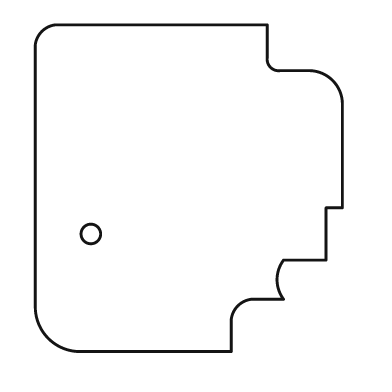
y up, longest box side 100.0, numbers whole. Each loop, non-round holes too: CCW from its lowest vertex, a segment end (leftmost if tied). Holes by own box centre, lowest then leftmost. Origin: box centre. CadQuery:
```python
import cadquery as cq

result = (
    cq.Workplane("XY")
    .moveTo(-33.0, -50.0)
    .lineTo(13.0, -50.0)
    .lineTo(13.0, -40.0)
    .threePointArc((15.0, -36.0), (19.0, -34.0))
    .lineTo(29.0, -34.0)
    .threePointArc((27.0, -28.0), (29.0, -22.0))
    .lineTo(42.0, -22.0)
    .lineTo(42.0, -6.0)
    .lineTo(47.0, -6.0)
    .lineTo(47.0, 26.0)
    .threePointArc((44.0, 33.0), (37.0, 36.0))
    .lineTo(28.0, 36.0)
    .threePointArc((25.0, 37.0), (24.0, 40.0))
    .lineTo(24.0, 50.0)
    .lineTo(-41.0, 50.0)
    .threePointArc((-45.0, 48.0), (-47.0, 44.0))
    .lineTo(-47.0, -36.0)
    .threePointArc((-43.0, -46.0), (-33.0, -50.0))
    .close()
    .moveTo(-30.0, -14.0)
    .circle(3.0)
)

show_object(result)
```